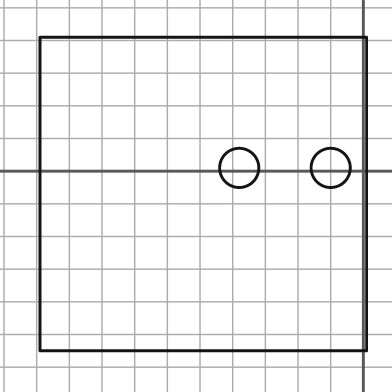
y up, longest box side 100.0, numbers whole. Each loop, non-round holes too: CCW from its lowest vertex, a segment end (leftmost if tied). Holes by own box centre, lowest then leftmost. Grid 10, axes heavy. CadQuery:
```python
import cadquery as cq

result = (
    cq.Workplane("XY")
    .moveTo(-99.0, -55.0)
    .lineTo(1.0, -55.0)
    .lineTo(1.0, 41.0)
    .lineTo(-99.0, 41.0)
    .close()
    .moveTo(-38.0, 1.0)
    .circle(6.0)
    .moveTo(-10.0, 1.0)
    .circle(6.0)
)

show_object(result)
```